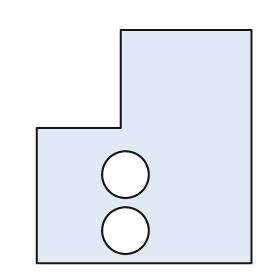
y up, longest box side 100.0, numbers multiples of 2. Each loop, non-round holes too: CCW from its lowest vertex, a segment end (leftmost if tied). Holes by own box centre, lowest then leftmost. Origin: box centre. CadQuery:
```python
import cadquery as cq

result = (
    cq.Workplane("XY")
    .moveTo(-46.0, -50.0)
    .lineTo(46.0, -50.0)
    .lineTo(46.0, 50.0)
    .lineTo(-10.0, 50.0)
    .lineTo(-10.0, 8.0)
    .lineTo(-46.0, 8.0)
    .close()
    .moveTo(-8.0, -36.0)
    .circle(10.0)
    .moveTo(-8.0, -12.0)
    .circle(10.0)
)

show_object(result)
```